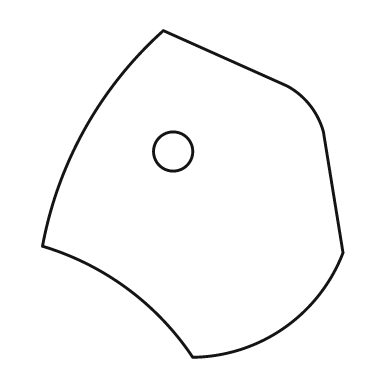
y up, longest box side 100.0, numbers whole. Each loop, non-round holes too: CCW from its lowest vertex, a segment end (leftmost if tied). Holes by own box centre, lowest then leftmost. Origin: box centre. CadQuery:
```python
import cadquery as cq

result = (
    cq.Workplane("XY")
    .moveTo(0.0, -50.0)
    .threePointArc((28.0, -41.0), (46.0, -18.0))
    .lineTo(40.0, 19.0)
    .threePointArc((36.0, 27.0), (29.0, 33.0))
    .lineTo(-9.0, 50.0)
    .threePointArc((-33.0, 20.0), (-46.0, -16.0))
    .threePointArc((-20.0, -29.0), (0.0, -50.0))
    .close()
    .moveTo(-6.0, 13.0)
    .circle(6.0)
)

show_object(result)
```